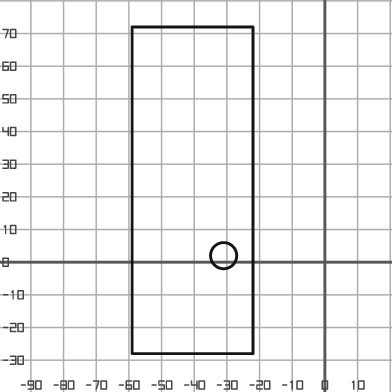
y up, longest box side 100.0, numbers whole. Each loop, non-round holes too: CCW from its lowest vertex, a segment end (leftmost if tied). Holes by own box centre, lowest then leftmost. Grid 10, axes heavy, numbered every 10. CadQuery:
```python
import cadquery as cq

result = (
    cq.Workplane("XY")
    .moveTo(-59.0, -28.0)
    .lineTo(-22.0, -28.0)
    .lineTo(-22.0, 72.0)
    .lineTo(-59.0, 72.0)
    .close()
    .moveTo(-31.0, 2.0)
    .circle(4.0)
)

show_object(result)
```